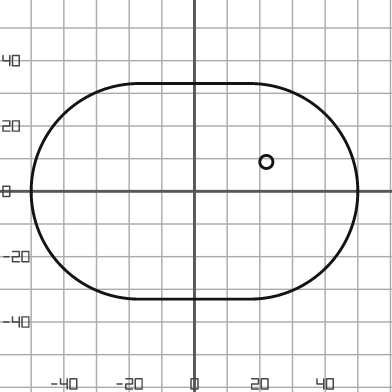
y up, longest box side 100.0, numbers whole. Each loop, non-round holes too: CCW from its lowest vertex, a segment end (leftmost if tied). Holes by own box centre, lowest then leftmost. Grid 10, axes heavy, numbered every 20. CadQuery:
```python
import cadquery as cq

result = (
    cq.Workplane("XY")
    .moveTo(-17.0, -33.0)
    .lineTo(17.0, -33.0)
    .threePointArc((50.0, 0.0), (17.0, 33.0))
    .lineTo(-17.0, 33.0)
    .threePointArc((-50.0, 0.0), (-17.0, -33.0))
    .close()
    .moveTo(22.0, 9.0)
    .circle(2.0)
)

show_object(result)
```